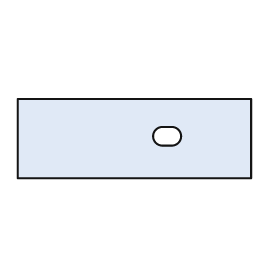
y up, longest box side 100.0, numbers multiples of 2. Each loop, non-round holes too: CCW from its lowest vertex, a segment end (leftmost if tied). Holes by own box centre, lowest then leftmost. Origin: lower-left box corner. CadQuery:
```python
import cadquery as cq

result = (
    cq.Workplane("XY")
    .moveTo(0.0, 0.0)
    .lineTo(100.0, 0.0)
    .lineTo(100.0, 34.0)
    .lineTo(0.0, 34.0)
    .close()
    .moveTo(62.0, 14.0)
    .lineTo(66.0, 14.0)
    .threePointArc((70.0, 18.0), (66.0, 22.0))
    .lineTo(62.0, 22.0)
    .threePointArc((58.0, 18.0), (62.0, 14.0))
    .close()
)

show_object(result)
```